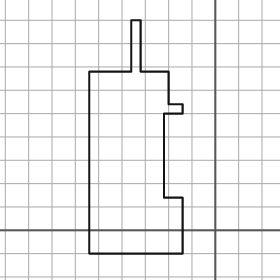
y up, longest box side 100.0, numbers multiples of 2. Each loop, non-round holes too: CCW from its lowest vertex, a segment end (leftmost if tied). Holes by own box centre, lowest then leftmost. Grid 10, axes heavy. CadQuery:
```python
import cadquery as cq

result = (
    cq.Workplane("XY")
    .moveTo(-54.0, -10.0)
    .lineTo(-14.0, -10.0)
    .lineTo(-14.0, 14.0)
    .lineTo(-22.0, 14.0)
    .lineTo(-22.0, 50.0)
    .lineTo(-14.0, 50.0)
    .lineTo(-14.0, 54.0)
    .lineTo(-20.0, 54.0)
    .lineTo(-20.0, 68.0)
    .lineTo(-32.0, 68.0)
    .lineTo(-32.0, 90.0)
    .lineTo(-36.0, 90.0)
    .lineTo(-36.0, 68.0)
    .lineTo(-54.0, 68.0)
    .close()
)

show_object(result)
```